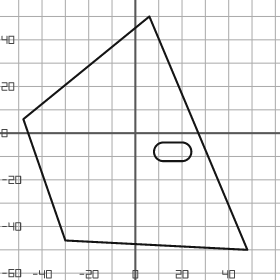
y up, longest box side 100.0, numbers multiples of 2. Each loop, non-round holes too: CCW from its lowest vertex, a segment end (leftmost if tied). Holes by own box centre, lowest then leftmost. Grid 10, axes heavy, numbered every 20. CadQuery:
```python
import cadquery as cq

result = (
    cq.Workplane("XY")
    .moveTo(48.0, -50.0)
    .lineTo(6.0, 50.0)
    .lineTo(-48.0, 6.0)
    .lineTo(-30.0, -46.0)
    .close()
    .moveTo(12.0, -12.0)
    .lineTo(20.0, -12.0)
    .threePointArc((24.0, -8.0), (20.0, -4.0))
    .lineTo(12.0, -4.0)
    .threePointArc((8.0, -8.0), (12.0, -12.0))
    .close()
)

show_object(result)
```